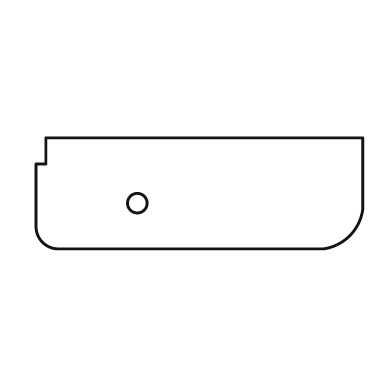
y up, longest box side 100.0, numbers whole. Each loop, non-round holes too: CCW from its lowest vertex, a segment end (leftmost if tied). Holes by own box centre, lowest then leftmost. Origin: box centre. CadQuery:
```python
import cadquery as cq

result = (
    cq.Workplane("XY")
    .moveTo(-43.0, -17.0)
    .lineTo(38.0, -17.0)
    .threePointArc((46.0, -13.0), (50.0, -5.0))
    .lineTo(50.0, 17.0)
    .lineTo(-47.0, 17.0)
    .lineTo(-47.0, 9.0)
    .lineTo(-50.0, 9.0)
    .lineTo(-50.0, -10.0)
    .threePointArc((-48.0, -15.0), (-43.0, -17.0))
    .close()
    .moveTo(-19.0, -3.0)
    .circle(3.0)
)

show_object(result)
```